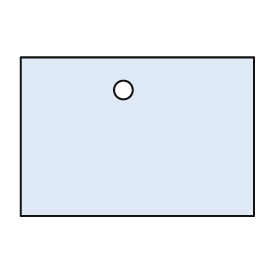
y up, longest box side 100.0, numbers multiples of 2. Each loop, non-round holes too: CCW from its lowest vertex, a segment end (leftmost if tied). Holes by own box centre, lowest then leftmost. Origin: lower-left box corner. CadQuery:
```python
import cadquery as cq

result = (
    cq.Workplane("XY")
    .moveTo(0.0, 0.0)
    .lineTo(100.0, 0.0)
    .lineTo(100.0, 68.0)
    .lineTo(0.0, 68.0)
    .close()
    .moveTo(44.0, 54.0)
    .circle(4.0)
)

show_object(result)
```